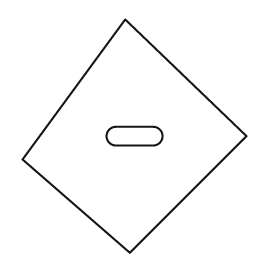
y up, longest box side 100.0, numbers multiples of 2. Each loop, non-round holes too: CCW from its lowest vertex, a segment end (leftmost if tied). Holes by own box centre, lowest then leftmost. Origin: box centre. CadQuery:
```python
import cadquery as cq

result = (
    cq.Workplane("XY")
    .moveTo(-2.0, -50.0)
    .lineTo(48.0, 0.0)
    .lineTo(-4.0, 50.0)
    .lineTo(-48.0, -10.0)
    .close()
    .moveTo(-8.0, -4.0)
    .lineTo(8.0, -4.0)
    .threePointArc((12.0, 0.0), (8.0, 4.0))
    .lineTo(-8.0, 4.0)
    .threePointArc((-12.0, 0.0), (-8.0, -4.0))
    .close()
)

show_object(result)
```